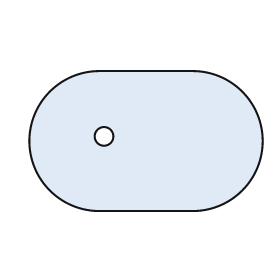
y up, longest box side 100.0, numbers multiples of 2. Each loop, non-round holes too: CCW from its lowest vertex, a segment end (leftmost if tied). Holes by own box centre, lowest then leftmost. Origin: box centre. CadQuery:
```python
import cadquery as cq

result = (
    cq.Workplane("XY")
    .moveTo(-20.0, -30.0)
    .lineTo(20.0, -30.0)
    .threePointArc((50.0, 0.0), (20.0, 30.0))
    .lineTo(-20.0, 30.0)
    .threePointArc((-50.0, 0.0), (-20.0, -30.0))
    .close()
    .moveTo(-18.0, 2.0)
    .circle(4.0)
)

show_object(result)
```